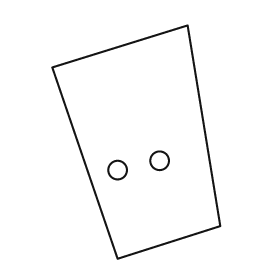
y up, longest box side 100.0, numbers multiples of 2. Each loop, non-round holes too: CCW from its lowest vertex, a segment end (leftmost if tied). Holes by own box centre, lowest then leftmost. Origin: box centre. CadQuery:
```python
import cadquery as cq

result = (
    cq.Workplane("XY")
    .moveTo(-8.0, -50.0)
    .lineTo(36.0, -36.0)
    .lineTo(22.0, 50.0)
    .lineTo(-36.0, 32.0)
    .close()
    .moveTo(-8.0, -12.0)
    .circle(4.0)
    .moveTo(10.0, -8.0)
    .circle(4.0)
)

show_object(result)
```